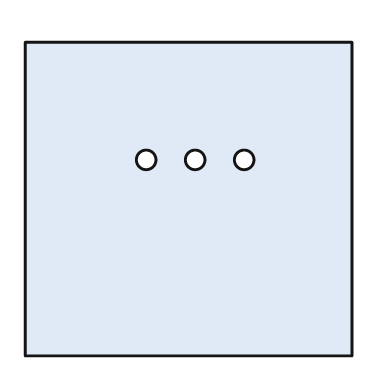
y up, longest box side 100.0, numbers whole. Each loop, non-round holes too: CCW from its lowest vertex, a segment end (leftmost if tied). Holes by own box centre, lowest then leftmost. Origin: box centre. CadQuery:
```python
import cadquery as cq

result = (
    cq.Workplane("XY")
    .moveTo(-50.0, -48.0)
    .lineTo(50.0, -48.0)
    .lineTo(50.0, 48.0)
    .lineTo(-50.0, 48.0)
    .close()
    .moveTo(-13.0, 12.0)
    .circle(3.0)
    .moveTo(2.0, 12.0)
    .circle(3.0)
    .moveTo(17.0, 12.0)
    .circle(3.0)
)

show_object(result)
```